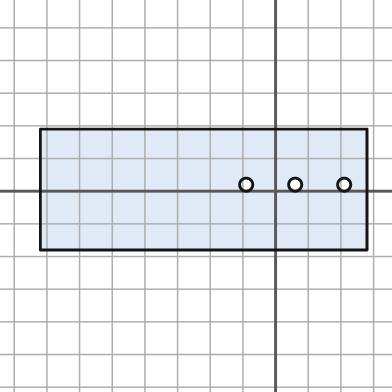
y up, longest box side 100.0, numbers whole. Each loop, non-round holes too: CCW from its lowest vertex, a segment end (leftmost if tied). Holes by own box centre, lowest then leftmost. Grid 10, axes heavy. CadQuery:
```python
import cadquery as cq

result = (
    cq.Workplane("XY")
    .moveTo(-72.0, -18.0)
    .lineTo(28.0, -18.0)
    .lineTo(28.0, 19.0)
    .lineTo(-72.0, 19.0)
    .close()
    .moveTo(-9.0, 2.0)
    .circle(2.0)
    .moveTo(6.0, 2.0)
    .circle(2.0)
    .moveTo(21.0, 2.0)
    .circle(2.0)
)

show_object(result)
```